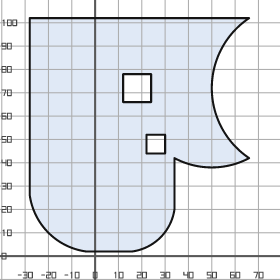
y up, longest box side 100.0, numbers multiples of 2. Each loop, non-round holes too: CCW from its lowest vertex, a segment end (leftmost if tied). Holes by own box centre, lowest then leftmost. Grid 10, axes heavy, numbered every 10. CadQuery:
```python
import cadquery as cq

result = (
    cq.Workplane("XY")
    .moveTo(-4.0, 2.0)
    .lineTo(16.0, 2.0)
    .threePointArc((28.0, 8.0), (34.0, 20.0))
    .lineTo(34.0, 42.0)
    .threePointArc((50.0, 38.0), (66.0, 42.0))
    .threePointArc((50.0, 72.0), (66.0, 102.0))
    .lineTo(-28.0, 102.0)
    .lineTo(-28.0, 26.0)
    .threePointArc((-20.0, 10.0), (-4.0, 2.0))
    .close()
    .moveTo(22.0, 44.0)
    .lineTo(30.0, 44.0)
    .lineTo(30.0, 52.0)
    .lineTo(22.0, 52.0)
    .close()
    .moveTo(12.0, 66.0)
    .lineTo(24.0, 66.0)
    .lineTo(24.0, 78.0)
    .lineTo(12.0, 78.0)
    .close()
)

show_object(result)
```